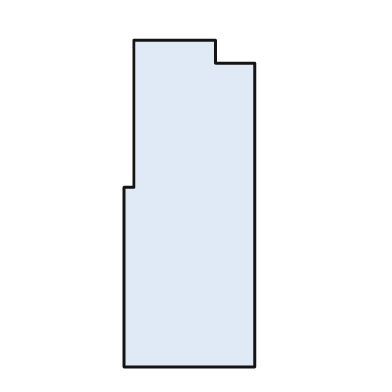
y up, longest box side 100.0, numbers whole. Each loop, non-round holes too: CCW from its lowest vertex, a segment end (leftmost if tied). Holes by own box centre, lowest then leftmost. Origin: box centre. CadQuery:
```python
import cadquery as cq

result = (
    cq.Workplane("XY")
    .moveTo(-20.0, -50.0)
    .lineTo(20.0, -50.0)
    .lineTo(20.0, 43.0)
    .lineTo(8.0, 43.0)
    .lineTo(8.0, 50.0)
    .lineTo(-17.0, 50.0)
    .lineTo(-17.0, 5.0)
    .lineTo(-20.0, 5.0)
    .close()
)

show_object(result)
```